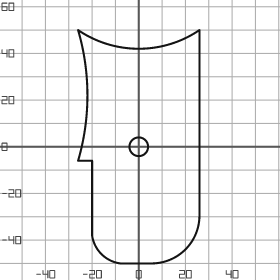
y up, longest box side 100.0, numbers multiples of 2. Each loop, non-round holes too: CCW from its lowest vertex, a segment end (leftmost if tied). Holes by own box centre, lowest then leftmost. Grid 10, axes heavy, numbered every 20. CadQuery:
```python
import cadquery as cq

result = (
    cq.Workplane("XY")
    .moveTo(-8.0, -50.0)
    .lineTo(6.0, -50.0)
    .threePointArc((20.0, -44.0), (26.0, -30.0))
    .lineTo(26.0, 50.0)
    .threePointArc((0.0, 42.0), (-26.0, 50.0))
    .threePointArc((-22.0, 22.0), (-26.0, -6.0))
    .lineTo(-20.0, -6.0)
    .lineTo(-20.0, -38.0)
    .threePointArc((-16.0, -46.0), (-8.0, -50.0))
    .close()
    .moveTo(0.0, 0.0)
    .circle(4.0)
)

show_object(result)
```